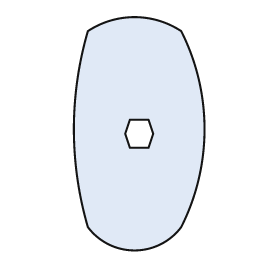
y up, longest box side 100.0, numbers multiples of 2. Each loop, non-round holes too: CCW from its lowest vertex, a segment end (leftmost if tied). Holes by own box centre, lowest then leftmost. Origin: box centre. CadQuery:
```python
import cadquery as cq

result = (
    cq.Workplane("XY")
    .moveTo(-22.0, -40.0)
    .threePointArc((-2.0, -50.0), (18.0, -40.0))
    .threePointArc((28.0, 2.0), (18.0, 44.0))
    .threePointArc((-2.0, 50.0), (-22.0, 44.0))
    .threePointArc((-28.0, 2.0), (-22.0, -40.0))
    .close()
    .moveTo(-4.0, -6.0)
    .lineTo(4.0, -6.0)
    .lineTo(6.0, 0.0)
    .lineTo(4.0, 6.0)
    .lineTo(-4.0, 6.0)
    .lineTo(-6.0, 0.0)
    .close()
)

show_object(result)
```